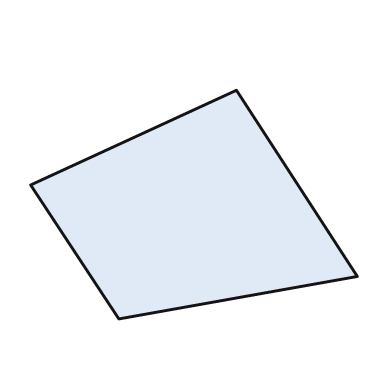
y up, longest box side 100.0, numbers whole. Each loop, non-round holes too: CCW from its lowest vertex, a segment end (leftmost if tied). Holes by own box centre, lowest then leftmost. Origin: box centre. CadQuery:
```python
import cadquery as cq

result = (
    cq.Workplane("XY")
    .moveTo(-23.0, -35.0)
    .lineTo(50.0, -22.0)
    .lineTo(13.0, 35.0)
    .lineTo(-50.0, 6.0)
    .close()
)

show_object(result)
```